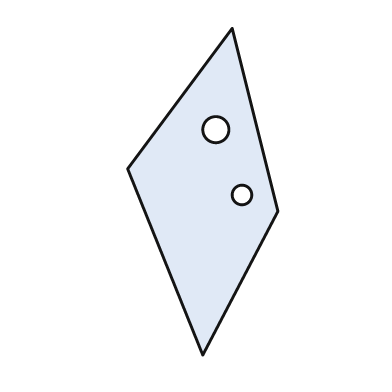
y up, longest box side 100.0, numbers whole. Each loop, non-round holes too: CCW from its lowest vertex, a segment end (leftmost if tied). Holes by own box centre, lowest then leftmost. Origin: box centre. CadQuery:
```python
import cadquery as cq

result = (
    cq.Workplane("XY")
    .moveTo(0.0, -50.0)
    .lineTo(23.0, -6.0)
    .lineTo(9.0, 50.0)
    .lineTo(-23.0, 7.0)
    .close()
    .moveTo(12.0, -1.0)
    .circle(3.0)
    .moveTo(4.0, 19.0)
    .circle(4.0)
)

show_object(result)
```